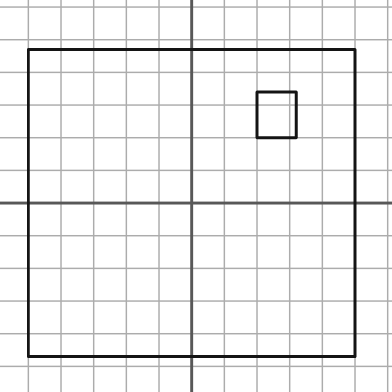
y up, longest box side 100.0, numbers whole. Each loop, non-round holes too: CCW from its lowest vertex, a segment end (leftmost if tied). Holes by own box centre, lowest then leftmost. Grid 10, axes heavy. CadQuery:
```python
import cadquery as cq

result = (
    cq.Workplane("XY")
    .moveTo(-50.0, -47.0)
    .lineTo(50.0, -47.0)
    .lineTo(50.0, 47.0)
    .lineTo(-50.0, 47.0)
    .close()
    .moveTo(20.0, 20.0)
    .lineTo(32.0, 20.0)
    .lineTo(32.0, 34.0)
    .lineTo(20.0, 34.0)
    .close()
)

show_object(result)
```